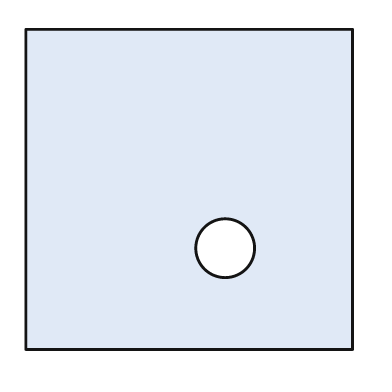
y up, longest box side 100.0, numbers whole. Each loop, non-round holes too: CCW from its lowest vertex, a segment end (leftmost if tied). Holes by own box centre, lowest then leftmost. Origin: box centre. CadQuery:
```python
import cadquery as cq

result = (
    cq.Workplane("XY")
    .moveTo(-50.0, -49.0)
    .lineTo(50.0, -49.0)
    .lineTo(50.0, 49.0)
    .lineTo(-50.0, 49.0)
    .close()
    .moveTo(11.0, -18.0)
    .circle(9.0)
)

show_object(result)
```